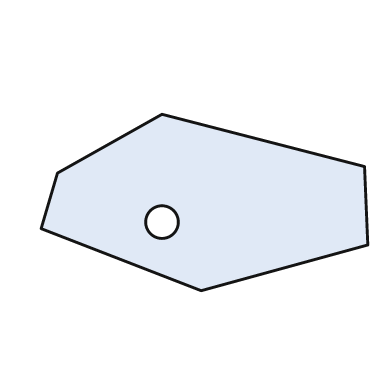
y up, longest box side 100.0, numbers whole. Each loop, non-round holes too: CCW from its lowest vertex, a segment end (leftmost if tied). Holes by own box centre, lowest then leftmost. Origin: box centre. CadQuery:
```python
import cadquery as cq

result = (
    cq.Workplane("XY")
    .moveTo(-1.0, -27.0)
    .lineTo(50.0, -13.0)
    .lineTo(49.0, 11.0)
    .lineTo(-13.0, 27.0)
    .lineTo(-45.0, 9.0)
    .lineTo(-50.0, -8.0)
    .close()
    .moveTo(-13.0, -6.0)
    .circle(5.0)
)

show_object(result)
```